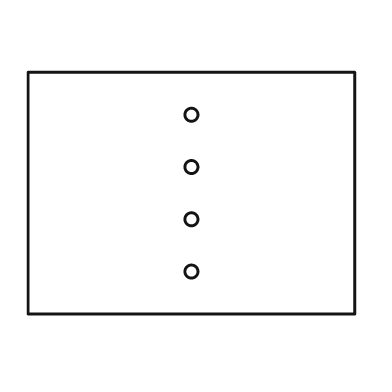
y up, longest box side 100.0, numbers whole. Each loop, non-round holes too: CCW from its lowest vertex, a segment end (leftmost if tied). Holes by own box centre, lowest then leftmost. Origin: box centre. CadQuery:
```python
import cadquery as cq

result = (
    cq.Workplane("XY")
    .moveTo(-50.0, -37.0)
    .lineTo(50.0, -37.0)
    .lineTo(50.0, 37.0)
    .lineTo(-50.0, 37.0)
    .close()
    .moveTo(0.0, -24.0)
    .circle(2.0)
    .moveTo(0.0, -8.0)
    .circle(2.0)
    .moveTo(0.0, 8.0)
    .circle(2.0)
    .moveTo(0.0, 24.0)
    .circle(2.0)
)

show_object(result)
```